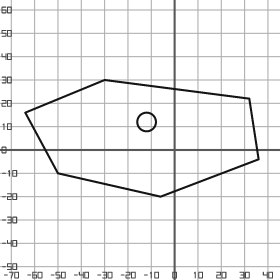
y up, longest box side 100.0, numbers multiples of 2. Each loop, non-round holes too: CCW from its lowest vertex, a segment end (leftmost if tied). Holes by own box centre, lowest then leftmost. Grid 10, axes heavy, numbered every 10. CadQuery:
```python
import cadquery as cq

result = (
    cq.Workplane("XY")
    .moveTo(-6.0, -20.0)
    .lineTo(36.0, -4.0)
    .lineTo(32.0, 22.0)
    .lineTo(-30.0, 30.0)
    .lineTo(-64.0, 16.0)
    .lineTo(-50.0, -10.0)
    .close()
    .moveTo(-12.0, 12.0)
    .circle(4.0)
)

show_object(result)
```